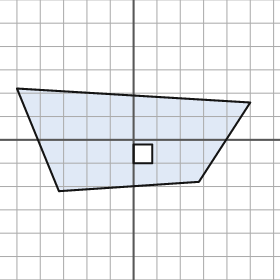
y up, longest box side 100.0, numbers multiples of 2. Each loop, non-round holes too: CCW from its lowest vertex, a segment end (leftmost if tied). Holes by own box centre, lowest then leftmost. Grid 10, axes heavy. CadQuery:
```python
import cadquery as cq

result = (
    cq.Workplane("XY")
    .moveTo(-32.0, -22.0)
    .lineTo(28.0, -18.0)
    .lineTo(50.0, 16.0)
    .lineTo(-50.0, 22.0)
    .close()
    .moveTo(0.0, -10.0)
    .lineTo(8.0, -10.0)
    .lineTo(8.0, -2.0)
    .lineTo(0.0, -2.0)
    .close()
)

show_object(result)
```